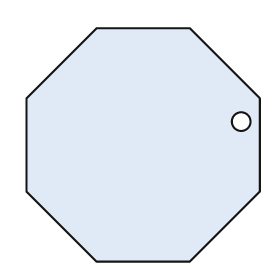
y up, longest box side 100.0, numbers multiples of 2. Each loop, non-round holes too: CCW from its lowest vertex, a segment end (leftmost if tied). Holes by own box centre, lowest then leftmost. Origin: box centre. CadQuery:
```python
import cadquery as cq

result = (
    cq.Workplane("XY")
    .moveTo(-20.0, -50.0)
    .lineTo(20.0, -50.0)
    .lineTo(50.0, -20.0)
    .lineTo(50.0, 20.0)
    .lineTo(20.0, 50.0)
    .lineTo(-20.0, 50.0)
    .lineTo(-50.0, 20.0)
    .lineTo(-50.0, -20.0)
    .close()
    .moveTo(42.0, 10.0)
    .circle(4.0)
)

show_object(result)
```